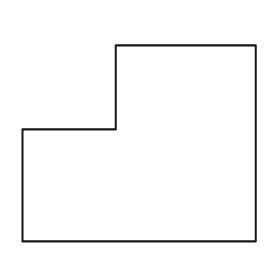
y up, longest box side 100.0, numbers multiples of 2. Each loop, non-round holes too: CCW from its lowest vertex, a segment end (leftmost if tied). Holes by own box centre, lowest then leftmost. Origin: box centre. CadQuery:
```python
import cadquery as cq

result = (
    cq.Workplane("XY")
    .moveTo(-50.0, -42.0)
    .lineTo(50.0, -42.0)
    .lineTo(50.0, 42.0)
    .lineTo(-10.0, 42.0)
    .lineTo(-10.0, 6.0)
    .lineTo(-50.0, 6.0)
    .close()
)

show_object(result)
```